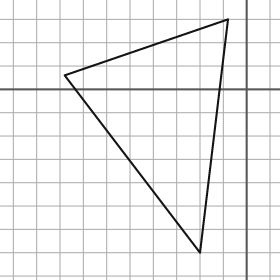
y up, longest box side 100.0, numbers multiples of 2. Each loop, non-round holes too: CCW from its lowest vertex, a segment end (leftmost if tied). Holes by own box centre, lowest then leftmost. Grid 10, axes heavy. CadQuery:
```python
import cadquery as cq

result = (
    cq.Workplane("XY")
    .moveTo(-20.0, -70.0)
    .lineTo(-8.0, 30.0)
    .lineTo(-78.0, 6.0)
    .close()
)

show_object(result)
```